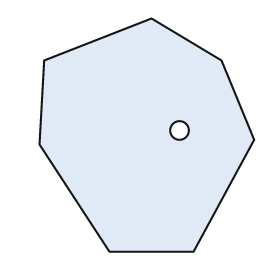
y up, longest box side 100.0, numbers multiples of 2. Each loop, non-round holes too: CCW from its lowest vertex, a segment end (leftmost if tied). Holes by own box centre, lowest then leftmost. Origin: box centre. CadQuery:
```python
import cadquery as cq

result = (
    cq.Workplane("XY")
    .moveTo(-16.0, -50.0)
    .lineTo(20.0, -50.0)
    .lineTo(46.0, -2.0)
    .lineTo(32.0, 32.0)
    .lineTo(2.0, 50.0)
    .lineTo(-44.0, 32.0)
    .lineTo(-46.0, -4.0)
    .close()
    .moveTo(14.0, 2.0)
    .circle(4.0)
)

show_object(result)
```